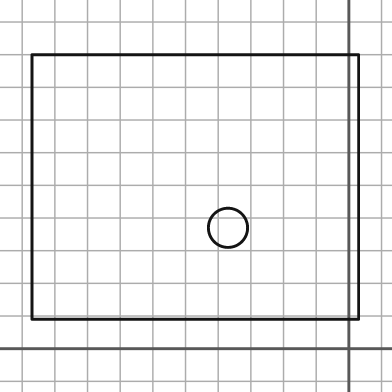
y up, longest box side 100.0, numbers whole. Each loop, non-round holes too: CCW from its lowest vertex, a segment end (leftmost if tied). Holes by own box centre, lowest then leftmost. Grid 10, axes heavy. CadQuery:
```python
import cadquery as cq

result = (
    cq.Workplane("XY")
    .moveTo(-97.0, 9.0)
    .lineTo(3.0, 9.0)
    .lineTo(3.0, 90.0)
    .lineTo(-97.0, 90.0)
    .close()
    .moveTo(-37.0, 37.0)
    .circle(6.0)
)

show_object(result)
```